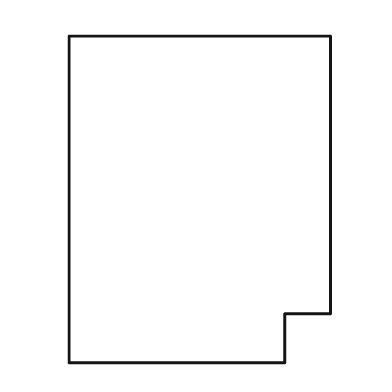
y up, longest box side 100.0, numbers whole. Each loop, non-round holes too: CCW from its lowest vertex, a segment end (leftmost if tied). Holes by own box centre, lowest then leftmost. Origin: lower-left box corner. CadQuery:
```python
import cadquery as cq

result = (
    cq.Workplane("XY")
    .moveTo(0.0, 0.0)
    .lineTo(66.0, 0.0)
    .lineTo(66.0, 15.0)
    .lineTo(80.0, 15.0)
    .lineTo(80.0, 100.0)
    .lineTo(0.0, 100.0)
    .close()
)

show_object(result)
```